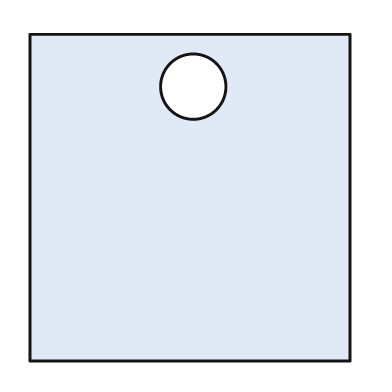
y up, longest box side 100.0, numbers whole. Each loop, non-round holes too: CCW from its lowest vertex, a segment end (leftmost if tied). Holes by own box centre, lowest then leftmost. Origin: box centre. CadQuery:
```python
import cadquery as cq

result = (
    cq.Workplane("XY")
    .moveTo(-49.0, -50.0)
    .lineTo(49.0, -50.0)
    .lineTo(49.0, 50.0)
    .lineTo(-49.0, 50.0)
    .close()
    .moveTo(1.0, 34.0)
    .circle(10.0)
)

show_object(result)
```